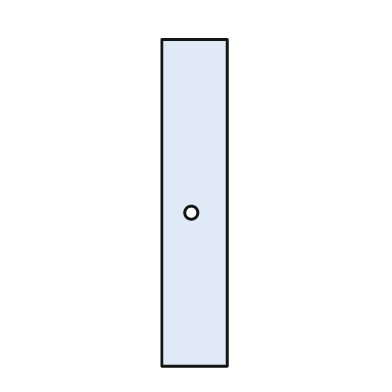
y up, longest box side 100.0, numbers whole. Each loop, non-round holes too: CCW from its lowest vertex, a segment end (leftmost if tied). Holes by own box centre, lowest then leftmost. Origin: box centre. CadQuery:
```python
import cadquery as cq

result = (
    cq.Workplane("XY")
    .moveTo(-10.0, -50.0)
    .lineTo(10.0, -50.0)
    .lineTo(10.0, 50.0)
    .lineTo(-10.0, 50.0)
    .close()
    .moveTo(-1.0, -3.0)
    .circle(2.0)
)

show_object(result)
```